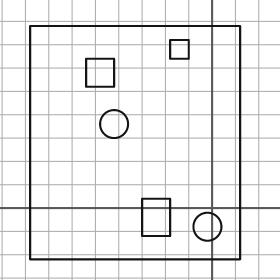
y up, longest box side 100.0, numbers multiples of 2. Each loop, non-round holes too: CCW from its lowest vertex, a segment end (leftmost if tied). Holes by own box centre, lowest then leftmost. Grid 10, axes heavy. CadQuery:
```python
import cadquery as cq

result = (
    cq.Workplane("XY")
    .moveTo(-78.0, -22.0)
    .lineTo(12.0, -22.0)
    .lineTo(12.0, 78.0)
    .lineTo(-78.0, 78.0)
    .close()
    .moveTo(-2.0, -8.0)
    .circle(6.0)
    .moveTo(-30.0, -12.0)
    .lineTo(-18.0, -12.0)
    .lineTo(-18.0, 4.0)
    .lineTo(-30.0, 4.0)
    .close()
    .moveTo(-42.0, 36.0)
    .circle(6.0)
    .moveTo(-54.0, 52.0)
    .lineTo(-42.0, 52.0)
    .lineTo(-42.0, 64.0)
    .lineTo(-54.0, 64.0)
    .close()
    .moveTo(-18.0, 64.0)
    .lineTo(-10.0, 64.0)
    .lineTo(-10.0, 72.0)
    .lineTo(-18.0, 72.0)
    .close()
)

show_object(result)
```